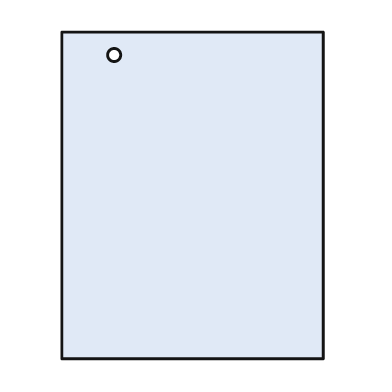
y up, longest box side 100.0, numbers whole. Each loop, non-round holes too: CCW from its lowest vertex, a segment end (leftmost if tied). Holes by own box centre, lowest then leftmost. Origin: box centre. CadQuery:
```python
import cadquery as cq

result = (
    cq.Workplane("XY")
    .moveTo(-40.0, -50.0)
    .lineTo(40.0, -50.0)
    .lineTo(40.0, 50.0)
    .lineTo(-40.0, 50.0)
    .close()
    .moveTo(-24.0, 43.0)
    .circle(2.0)
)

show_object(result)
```